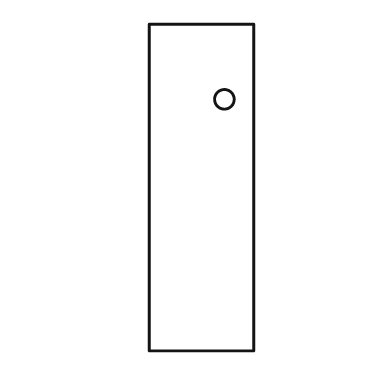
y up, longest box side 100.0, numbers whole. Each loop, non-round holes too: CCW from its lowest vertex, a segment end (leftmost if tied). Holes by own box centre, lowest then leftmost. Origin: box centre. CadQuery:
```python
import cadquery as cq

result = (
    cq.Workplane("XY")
    .moveTo(-16.0, -50.0)
    .lineTo(16.0, -50.0)
    .lineTo(16.0, 50.0)
    .lineTo(-16.0, 50.0)
    .close()
    .moveTo(7.0, 27.0)
    .circle(3.0)
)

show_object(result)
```